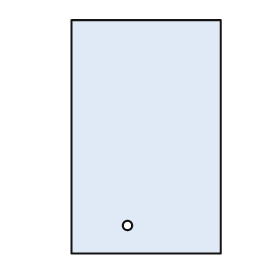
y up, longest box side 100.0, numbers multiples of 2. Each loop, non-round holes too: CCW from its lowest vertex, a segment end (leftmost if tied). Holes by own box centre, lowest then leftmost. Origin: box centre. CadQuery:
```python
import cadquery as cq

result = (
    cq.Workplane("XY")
    .moveTo(-32.0, -50.0)
    .lineTo(32.0, -50.0)
    .lineTo(32.0, 50.0)
    .lineTo(-32.0, 50.0)
    .close()
    .moveTo(-8.0, -38.0)
    .circle(2.0)
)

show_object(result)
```